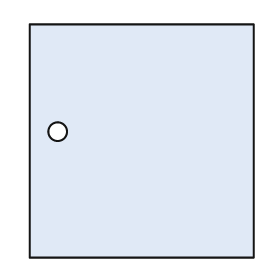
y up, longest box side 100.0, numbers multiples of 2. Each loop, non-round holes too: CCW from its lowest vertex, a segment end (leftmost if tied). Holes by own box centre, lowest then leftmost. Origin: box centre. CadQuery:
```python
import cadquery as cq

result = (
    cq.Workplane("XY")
    .moveTo(-48.0, -50.0)
    .lineTo(48.0, -50.0)
    .lineTo(48.0, 50.0)
    .lineTo(-48.0, 50.0)
    .close()
    .moveTo(-36.0, 4.0)
    .circle(4.0)
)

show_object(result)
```